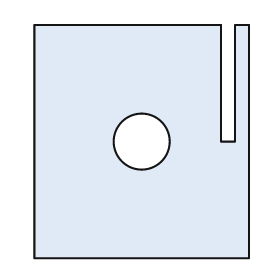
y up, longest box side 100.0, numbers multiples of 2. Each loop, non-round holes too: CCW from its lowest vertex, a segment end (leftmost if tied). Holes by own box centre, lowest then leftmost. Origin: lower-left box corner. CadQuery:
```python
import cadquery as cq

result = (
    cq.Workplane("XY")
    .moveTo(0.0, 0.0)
    .lineTo(92.0, 0.0)
    .lineTo(92.0, 100.0)
    .lineTo(86.0, 100.0)
    .lineTo(86.0, 50.0)
    .lineTo(80.0, 50.0)
    .lineTo(80.0, 100.0)
    .lineTo(0.0, 100.0)
    .close()
    .moveTo(46.0, 50.0)
    .circle(12.0)
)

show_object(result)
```